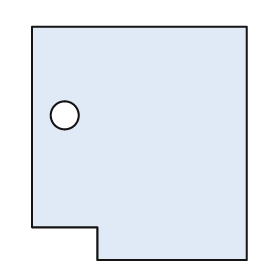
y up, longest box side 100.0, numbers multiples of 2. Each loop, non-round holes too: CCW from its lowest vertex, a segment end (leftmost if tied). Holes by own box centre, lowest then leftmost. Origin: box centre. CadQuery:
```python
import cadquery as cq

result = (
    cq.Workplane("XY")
    .moveTo(-18.0, -50.0)
    .lineTo(46.0, -50.0)
    .lineTo(46.0, 50.0)
    .lineTo(-46.0, 50.0)
    .lineTo(-46.0, -36.0)
    .lineTo(-18.0, -36.0)
    .close()
    .moveTo(-32.0, 12.0)
    .circle(6.0)
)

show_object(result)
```